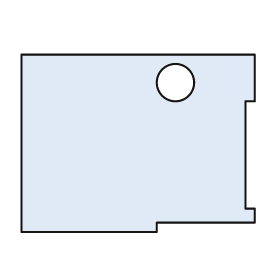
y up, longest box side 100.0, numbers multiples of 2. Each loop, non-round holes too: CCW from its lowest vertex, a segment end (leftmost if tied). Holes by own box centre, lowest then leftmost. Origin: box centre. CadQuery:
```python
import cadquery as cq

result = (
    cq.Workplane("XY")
    .moveTo(-50.0, -38.0)
    .lineTo(8.0, -38.0)
    .lineTo(8.0, -34.0)
    .lineTo(50.0, -34.0)
    .lineTo(50.0, -28.0)
    .lineTo(46.0, -28.0)
    .lineTo(46.0, 18.0)
    .lineTo(50.0, 18.0)
    .lineTo(50.0, 38.0)
    .lineTo(-50.0, 38.0)
    .close()
    .moveTo(16.0, 26.0)
    .circle(8.0)
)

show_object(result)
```